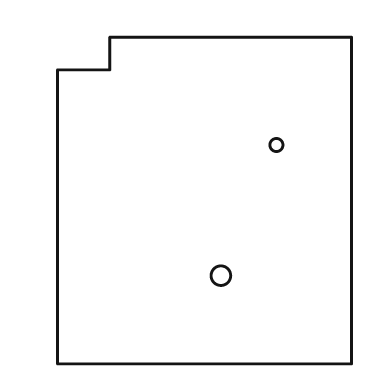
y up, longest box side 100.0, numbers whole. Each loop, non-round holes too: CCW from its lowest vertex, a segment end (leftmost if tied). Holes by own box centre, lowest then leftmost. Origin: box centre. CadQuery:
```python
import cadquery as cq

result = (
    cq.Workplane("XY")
    .moveTo(-45.0, -50.0)
    .lineTo(45.0, -50.0)
    .lineTo(45.0, 50.0)
    .lineTo(-29.0, 50.0)
    .lineTo(-29.0, 40.0)
    .lineTo(-45.0, 40.0)
    .close()
    .moveTo(5.0, -23.0)
    .circle(3.0)
    .moveTo(22.0, 17.0)
    .circle(2.0)
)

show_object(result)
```